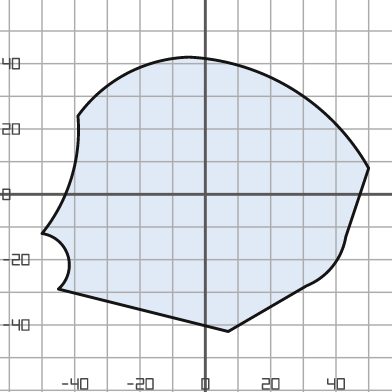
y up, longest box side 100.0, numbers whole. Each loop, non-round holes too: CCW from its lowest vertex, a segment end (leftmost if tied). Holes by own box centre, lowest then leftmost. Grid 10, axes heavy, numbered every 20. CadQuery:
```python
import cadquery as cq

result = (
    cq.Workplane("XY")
    .moveTo(7.0, -42.0)
    .lineTo(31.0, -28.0)
    .threePointArc((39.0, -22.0), (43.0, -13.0))
    .lineTo(50.0, 8.0)
    .threePointArc((27.0, 32.0), (-5.0, 42.0))
    .threePointArc((-24.0, 37.0), (-39.0, 24.0))
    .threePointArc((-41.0, 5.0), (-50.0, -12.0))
    .threePointArc((-42.0, -19.0), (-45.0, -29.0))
    .close()
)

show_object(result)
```